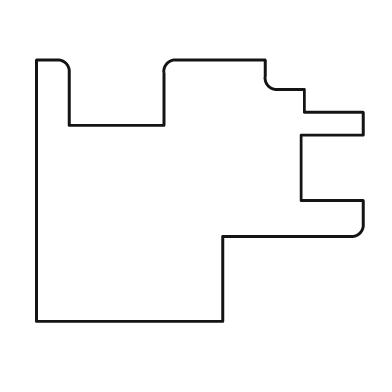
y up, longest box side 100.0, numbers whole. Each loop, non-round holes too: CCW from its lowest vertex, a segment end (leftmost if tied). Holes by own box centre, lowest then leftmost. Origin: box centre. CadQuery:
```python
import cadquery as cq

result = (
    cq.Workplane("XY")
    .moveTo(-50.0, -40.0)
    .lineTo(7.0, -40.0)
    .lineTo(7.0, -14.0)
    .lineTo(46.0, -14.0)
    .threePointArc((49.0, -13.0), (50.0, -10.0))
    .lineTo(50.0, -3.0)
    .lineTo(31.0, -3.0)
    .lineTo(31.0, 17.0)
    .lineTo(50.0, 17.0)
    .lineTo(50.0, 24.0)
    .lineTo(32.0, 24.0)
    .lineTo(32.0, 31.0)
    .lineTo(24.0, 31.0)
    .threePointArc((21.0, 32.0), (20.0, 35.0))
    .lineTo(20.0, 40.0)
    .lineTo(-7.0, 40.0)
    .threePointArc((-10.0, 39.0), (-11.0, 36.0))
    .lineTo(-11.0, 20.0)
    .lineTo(-40.0, 20.0)
    .lineTo(-40.0, 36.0)
    .threePointArc((-41.0, 39.0), (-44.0, 40.0))
    .lineTo(-50.0, 40.0)
    .close()
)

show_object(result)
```